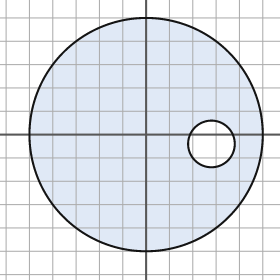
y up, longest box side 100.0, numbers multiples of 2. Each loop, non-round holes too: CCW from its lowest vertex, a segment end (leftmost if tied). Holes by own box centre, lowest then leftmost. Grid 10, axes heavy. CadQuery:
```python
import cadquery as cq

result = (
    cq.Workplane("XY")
    .moveTo(0.0, 0.0)
    .circle(50.0)
    .moveTo(28.0, -4.0)
    .circle(10.0)
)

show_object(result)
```